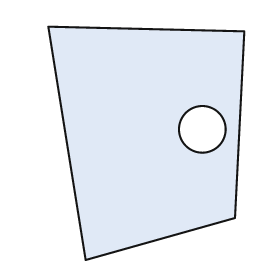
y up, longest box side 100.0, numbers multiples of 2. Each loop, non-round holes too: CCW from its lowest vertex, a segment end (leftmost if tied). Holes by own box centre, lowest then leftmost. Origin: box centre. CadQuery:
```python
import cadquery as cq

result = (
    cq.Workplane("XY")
    .moveTo(-26.0, -50.0)
    .lineTo(38.0, -32.0)
    .lineTo(42.0, 48.0)
    .lineTo(-42.0, 50.0)
    .close()
    .moveTo(24.0, 6.0)
    .circle(10.0)
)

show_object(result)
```